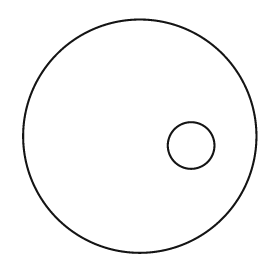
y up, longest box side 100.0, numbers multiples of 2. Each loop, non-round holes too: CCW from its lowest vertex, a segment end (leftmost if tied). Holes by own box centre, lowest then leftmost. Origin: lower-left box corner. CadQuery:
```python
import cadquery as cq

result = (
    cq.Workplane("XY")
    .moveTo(50.0, 50.0)
    .circle(50.0)
    .moveTo(72.0, 46.0)
    .circle(10.0)
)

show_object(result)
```